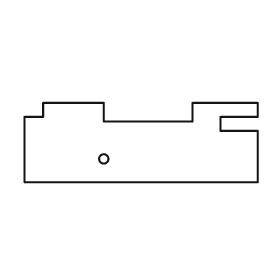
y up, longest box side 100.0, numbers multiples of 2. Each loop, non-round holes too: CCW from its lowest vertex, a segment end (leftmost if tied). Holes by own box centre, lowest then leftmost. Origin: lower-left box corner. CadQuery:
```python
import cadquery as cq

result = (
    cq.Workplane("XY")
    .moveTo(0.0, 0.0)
    .lineTo(100.0, 0.0)
    .lineTo(100.0, 22.0)
    .lineTo(84.0, 22.0)
    .lineTo(84.0, 28.0)
    .lineTo(100.0, 28.0)
    .lineTo(100.0, 34.0)
    .lineTo(72.0, 34.0)
    .lineTo(72.0, 26.0)
    .lineTo(34.0, 26.0)
    .lineTo(34.0, 34.0)
    .lineTo(8.0, 34.0)
    .lineTo(8.0, 28.0)
    .lineTo(0.0, 28.0)
    .close()
    .moveTo(34.0, 10.0)
    .circle(2.0)
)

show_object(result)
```